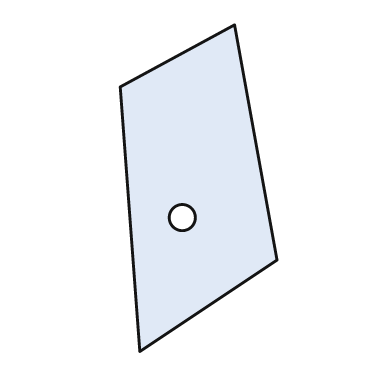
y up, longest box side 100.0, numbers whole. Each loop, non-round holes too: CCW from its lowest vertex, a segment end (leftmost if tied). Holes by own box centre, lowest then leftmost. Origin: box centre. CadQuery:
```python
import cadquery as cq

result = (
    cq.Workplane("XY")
    .moveTo(-18.0, -50.0)
    .lineTo(24.0, -22.0)
    .lineTo(11.0, 50.0)
    .lineTo(-24.0, 31.0)
    .close()
    .moveTo(-5.0, -9.0)
    .circle(4.0)
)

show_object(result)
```